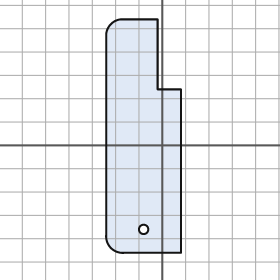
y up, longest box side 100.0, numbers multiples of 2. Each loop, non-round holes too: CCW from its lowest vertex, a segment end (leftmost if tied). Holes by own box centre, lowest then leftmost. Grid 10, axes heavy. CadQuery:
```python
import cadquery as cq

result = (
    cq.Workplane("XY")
    .moveTo(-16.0, -46.0)
    .lineTo(8.0, -46.0)
    .lineTo(8.0, 24.0)
    .lineTo(-2.0, 24.0)
    .lineTo(-2.0, 54.0)
    .lineTo(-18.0, 54.0)
    .threePointArc((-22.0, 52.0), (-24.0, 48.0))
    .lineTo(-24.0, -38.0)
    .threePointArc((-22.0, -44.0), (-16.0, -46.0))
    .close()
    .moveTo(-8.0, -36.0)
    .circle(2.0)
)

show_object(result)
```